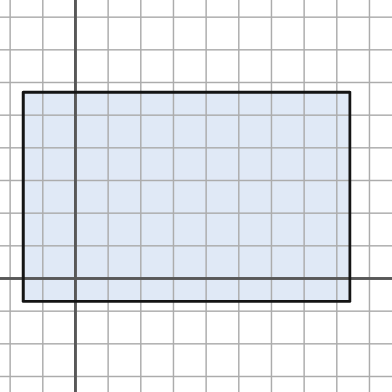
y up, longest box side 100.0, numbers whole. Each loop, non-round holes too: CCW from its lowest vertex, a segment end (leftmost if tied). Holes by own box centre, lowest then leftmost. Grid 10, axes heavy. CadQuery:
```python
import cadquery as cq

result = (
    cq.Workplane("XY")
    .moveTo(-16.0, -7.0)
    .lineTo(84.0, -7.0)
    .lineTo(84.0, 57.0)
    .lineTo(-16.0, 57.0)
    .close()
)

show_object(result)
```